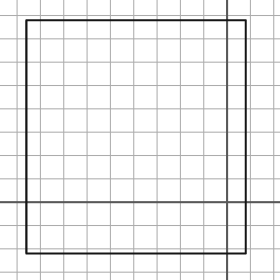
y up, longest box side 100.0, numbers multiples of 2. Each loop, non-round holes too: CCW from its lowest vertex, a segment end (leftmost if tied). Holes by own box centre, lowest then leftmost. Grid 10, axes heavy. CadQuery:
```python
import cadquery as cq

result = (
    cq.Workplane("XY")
    .moveTo(-86.0, -22.0)
    .lineTo(8.0, -22.0)
    .lineTo(8.0, 78.0)
    .lineTo(-86.0, 78.0)
    .close()
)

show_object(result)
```